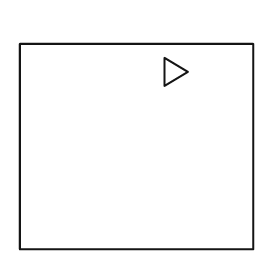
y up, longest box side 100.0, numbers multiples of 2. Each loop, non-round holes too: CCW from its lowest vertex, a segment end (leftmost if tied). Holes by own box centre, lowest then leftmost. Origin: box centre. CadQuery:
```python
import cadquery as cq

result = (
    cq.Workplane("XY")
    .moveTo(-50.0, -44.0)
    .lineTo(50.0, -44.0)
    .lineTo(50.0, 44.0)
    .lineTo(-50.0, 44.0)
    .close()
    .moveTo(12.0, 26.0)
    .lineTo(22.0, 32.0)
    .lineTo(12.0, 38.0)
    .close()
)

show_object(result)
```